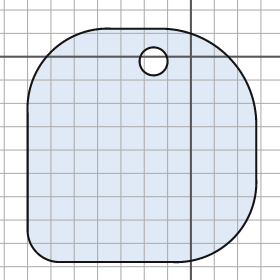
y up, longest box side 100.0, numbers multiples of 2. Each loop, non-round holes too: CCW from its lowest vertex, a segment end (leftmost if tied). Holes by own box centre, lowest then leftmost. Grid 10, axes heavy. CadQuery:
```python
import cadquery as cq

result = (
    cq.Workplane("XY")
    .moveTo(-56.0, -88.0)
    .lineTo(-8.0, -88.0)
    .threePointArc((18.0, -78.0), (28.0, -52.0))
    .lineTo(28.0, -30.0)
    .threePointArc((16.0, 0.0), (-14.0, 12.0))
    .lineTo(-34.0, 12.0)
    .threePointArc((-60.0, 2.0), (-70.0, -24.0))
    .lineTo(-70.0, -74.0)
    .threePointArc((-66.0, -84.0), (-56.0, -88.0))
    .close()
    .moveTo(-16.0, -2.0)
    .circle(6.0)
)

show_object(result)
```